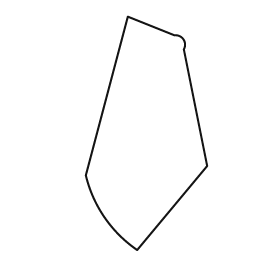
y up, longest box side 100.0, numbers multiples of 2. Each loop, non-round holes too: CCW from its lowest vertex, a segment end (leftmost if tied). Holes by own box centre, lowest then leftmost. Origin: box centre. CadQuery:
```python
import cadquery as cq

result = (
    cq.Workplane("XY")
    .moveTo(-4.0, -50.0)
    .lineTo(26.0, -14.0)
    .lineTo(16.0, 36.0)
    .threePointArc((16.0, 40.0), (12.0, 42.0))
    .lineTo(-8.0, 50.0)
    .lineTo(-26.0, -18.0)
    .threePointArc((-18.0, -36.0), (-4.0, -50.0))
    .close()
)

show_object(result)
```